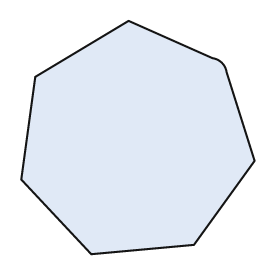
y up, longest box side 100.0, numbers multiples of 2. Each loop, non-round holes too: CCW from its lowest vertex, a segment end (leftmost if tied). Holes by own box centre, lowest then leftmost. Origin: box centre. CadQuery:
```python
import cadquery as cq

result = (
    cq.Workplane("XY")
    .moveTo(-20.0, -50.0)
    .lineTo(24.0, -46.0)
    .lineTo(50.0, -10.0)
    .lineTo(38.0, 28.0)
    .threePointArc((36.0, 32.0), (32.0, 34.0))
    .lineTo(-4.0, 50.0)
    .lineTo(-44.0, 26.0)
    .lineTo(-50.0, -18.0)
    .close()
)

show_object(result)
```